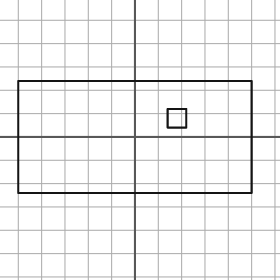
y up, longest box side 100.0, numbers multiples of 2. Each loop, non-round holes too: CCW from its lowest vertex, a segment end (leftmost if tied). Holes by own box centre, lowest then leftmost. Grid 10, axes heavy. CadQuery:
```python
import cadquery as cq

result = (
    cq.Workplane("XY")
    .moveTo(-50.0, -24.0)
    .lineTo(50.0, -24.0)
    .lineTo(50.0, 24.0)
    .lineTo(-50.0, 24.0)
    .close()
    .moveTo(14.0, 4.0)
    .lineTo(22.0, 4.0)
    .lineTo(22.0, 12.0)
    .lineTo(14.0, 12.0)
    .close()
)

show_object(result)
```